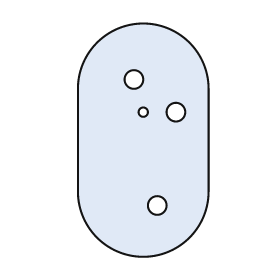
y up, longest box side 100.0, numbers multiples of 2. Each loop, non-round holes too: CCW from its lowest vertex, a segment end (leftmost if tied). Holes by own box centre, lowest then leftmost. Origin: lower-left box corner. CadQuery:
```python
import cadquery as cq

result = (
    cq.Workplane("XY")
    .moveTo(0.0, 28.0)
    .threePointArc((28.0, 0.0), (56.0, 28.0))
    .lineTo(56.0, 72.0)
    .threePointArc((28.0, 100.0), (0.0, 72.0))
    .close()
    .moveTo(34.0, 22.0)
    .circle(4.0)
    .moveTo(28.0, 62.0)
    .circle(2.0)
    .moveTo(42.0, 62.0)
    .circle(4.0)
    .moveTo(24.0, 76.0)
    .circle(4.0)
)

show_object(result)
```